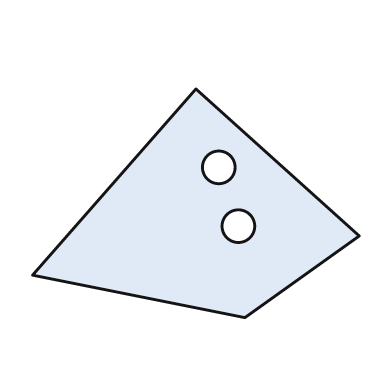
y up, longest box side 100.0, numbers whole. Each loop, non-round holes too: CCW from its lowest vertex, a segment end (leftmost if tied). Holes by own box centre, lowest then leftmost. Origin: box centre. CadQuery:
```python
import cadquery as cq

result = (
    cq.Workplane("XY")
    .moveTo(15.0, -35.0)
    .lineTo(50.0, -10.0)
    .lineTo(0.0, 35.0)
    .lineTo(-50.0, -22.0)
    .close()
    .moveTo(13.0, -7.0)
    .circle(5.0)
    .moveTo(7.0, 11.0)
    .circle(5.0)
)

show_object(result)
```